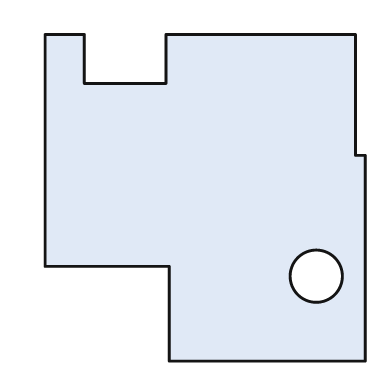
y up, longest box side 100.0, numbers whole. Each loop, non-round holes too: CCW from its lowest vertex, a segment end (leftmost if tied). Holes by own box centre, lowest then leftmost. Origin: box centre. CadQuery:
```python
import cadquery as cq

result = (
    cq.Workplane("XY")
    .moveTo(-11.0, -50.0)
    .lineTo(49.0, -50.0)
    .lineTo(49.0, 13.0)
    .lineTo(46.0, 13.0)
    .lineTo(46.0, 50.0)
    .lineTo(-12.0, 50.0)
    .lineTo(-12.0, 35.0)
    .lineTo(-37.0, 35.0)
    .lineTo(-37.0, 50.0)
    .lineTo(-49.0, 50.0)
    .lineTo(-49.0, -21.0)
    .lineTo(-11.0, -21.0)
    .close()
    .moveTo(34.0, -24.0)
    .circle(8.0)
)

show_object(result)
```